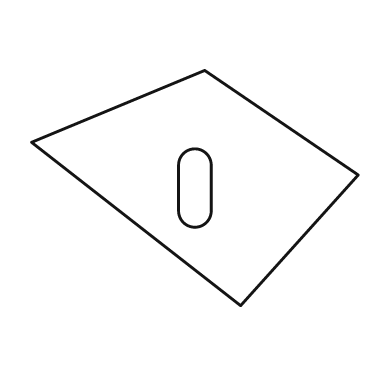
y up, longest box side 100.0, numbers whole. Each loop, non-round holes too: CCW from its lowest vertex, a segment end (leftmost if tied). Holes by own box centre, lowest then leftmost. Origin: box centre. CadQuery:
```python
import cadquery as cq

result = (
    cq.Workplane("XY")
    .moveTo(14.0, -36.0)
    .lineTo(50.0, 4.0)
    .lineTo(3.0, 36.0)
    .lineTo(-50.0, 14.0)
    .close()
    .moveTo(-5.0, -7.0)
    .threePointArc((0.0, -12.0), (5.0, -7.0))
    .lineTo(5.0, 7.0)
    .threePointArc((0.0, 12.0), (-5.0, 7.0))
    .close()
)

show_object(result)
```